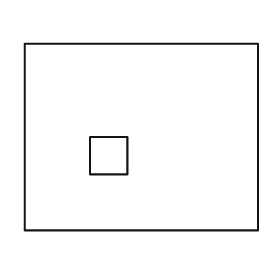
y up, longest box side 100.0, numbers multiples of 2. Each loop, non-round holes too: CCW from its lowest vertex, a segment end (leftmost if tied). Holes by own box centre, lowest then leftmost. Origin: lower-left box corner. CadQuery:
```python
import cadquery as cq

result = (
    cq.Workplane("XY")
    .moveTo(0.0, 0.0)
    .lineTo(100.0, 0.0)
    .lineTo(100.0, 80.0)
    .lineTo(0.0, 80.0)
    .close()
    .moveTo(28.0, 24.0)
    .lineTo(44.0, 24.0)
    .lineTo(44.0, 40.0)
    .lineTo(28.0, 40.0)
    .close()
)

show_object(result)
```